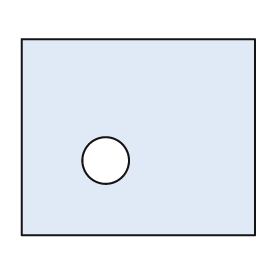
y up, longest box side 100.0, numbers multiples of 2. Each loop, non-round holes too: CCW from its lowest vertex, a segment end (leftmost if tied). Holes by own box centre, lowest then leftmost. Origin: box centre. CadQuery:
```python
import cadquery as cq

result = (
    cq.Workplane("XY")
    .moveTo(-50.0, -42.0)
    .lineTo(50.0, -42.0)
    .lineTo(50.0, 42.0)
    .lineTo(-50.0, 42.0)
    .close()
    .moveTo(-14.0, -10.0)
    .circle(10.0)
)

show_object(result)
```